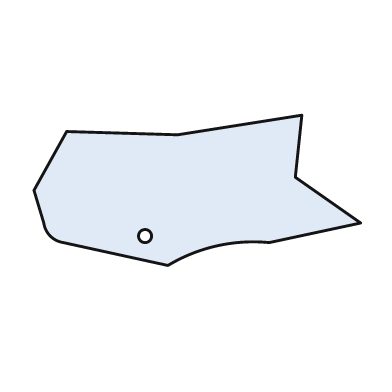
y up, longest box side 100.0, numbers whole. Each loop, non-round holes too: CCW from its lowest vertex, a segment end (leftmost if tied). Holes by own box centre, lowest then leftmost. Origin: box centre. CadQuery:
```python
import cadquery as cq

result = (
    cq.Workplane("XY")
    .moveTo(-9.0, -23.0)
    .threePointArc((6.0, -17.0), (22.0, -16.0))
    .lineTo(50.0, -10.0)
    .lineTo(30.0, 4.0)
    .lineTo(32.0, 23.0)
    .lineTo(-6.0, 17.0)
    .lineTo(-40.0, 18.0)
    .lineTo(-50.0, 0.0)
    .lineTo(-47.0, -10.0)
    .threePointArc((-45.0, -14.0), (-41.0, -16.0))
    .close()
    .moveTo(-16.0, -14.0)
    .circle(2.0)
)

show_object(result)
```